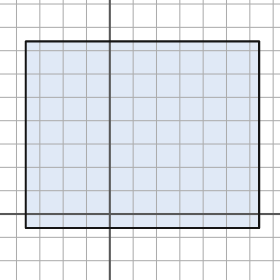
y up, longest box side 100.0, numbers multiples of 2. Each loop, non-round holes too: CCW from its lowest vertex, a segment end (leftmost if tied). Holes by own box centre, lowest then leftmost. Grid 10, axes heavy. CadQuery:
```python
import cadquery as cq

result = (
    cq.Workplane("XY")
    .moveTo(-36.0, -6.0)
    .lineTo(64.0, -6.0)
    .lineTo(64.0, 74.0)
    .lineTo(-36.0, 74.0)
    .close()
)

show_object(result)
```